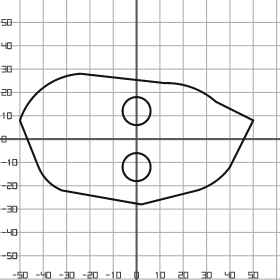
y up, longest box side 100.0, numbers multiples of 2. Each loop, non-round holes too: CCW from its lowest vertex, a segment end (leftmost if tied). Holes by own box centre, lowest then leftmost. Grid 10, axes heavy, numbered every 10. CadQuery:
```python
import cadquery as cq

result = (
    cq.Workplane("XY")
    .moveTo(2.0, -28.0)
    .lineTo(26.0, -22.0)
    .threePointArc((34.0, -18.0), (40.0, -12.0))
    .lineTo(50.0, 8.0)
    .lineTo(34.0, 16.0)
    .threePointArc((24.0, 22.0), (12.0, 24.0))
    .lineTo(-24.0, 28.0)
    .threePointArc((-40.0, 22.0), (-50.0, 8.0))
    .lineTo(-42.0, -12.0)
    .threePointArc((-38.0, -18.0), (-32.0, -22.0))
    .close()
    .moveTo(0.0, -12.0)
    .circle(6.0)
    .moveTo(0.0, 12.0)
    .circle(6.0)
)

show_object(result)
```